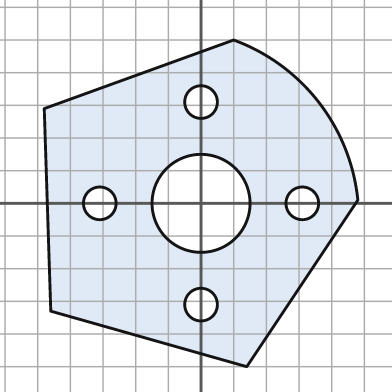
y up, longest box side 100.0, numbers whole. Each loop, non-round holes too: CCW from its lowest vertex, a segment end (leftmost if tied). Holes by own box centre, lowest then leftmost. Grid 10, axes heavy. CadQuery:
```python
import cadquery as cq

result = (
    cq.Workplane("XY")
    .moveTo(14.0, -50.0)
    .lineTo(48.0, 1.0)
    .threePointArc((36.0, 31.0), (10.0, 50.0))
    .lineTo(-48.0, 29.0)
    .lineTo(-46.0, -33.0)
    .close()
    .moveTo(0.0, -31.0)
    .circle(5.0)
    .moveTo(-31.0, 0.0)
    .circle(5.0)
    .moveTo(0.0, 0.0)
    .circle(15.0)
    .moveTo(31.0, 0.0)
    .circle(5.0)
    .moveTo(0.0, 31.0)
    .circle(5.0)
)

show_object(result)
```